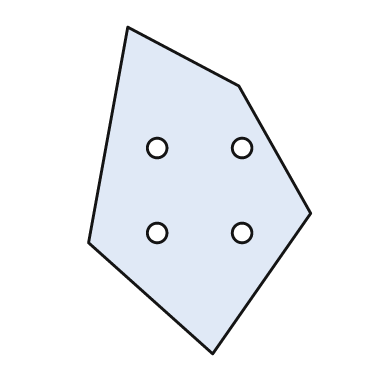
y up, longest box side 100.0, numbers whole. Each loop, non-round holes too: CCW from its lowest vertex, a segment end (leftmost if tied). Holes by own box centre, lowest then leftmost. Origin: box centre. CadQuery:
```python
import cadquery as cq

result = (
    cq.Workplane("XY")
    .moveTo(4.0, -50.0)
    .lineTo(34.0, -7.0)
    .lineTo(12.0, 32.0)
    .lineTo(-22.0, 50.0)
    .lineTo(-34.0, -16.0)
    .close()
    .moveTo(-13.0, -13.0)
    .circle(3.0)
    .moveTo(13.0, -13.0)
    .circle(3.0)
    .moveTo(-13.0, 13.0)
    .circle(3.0)
    .moveTo(13.0, 13.0)
    .circle(3.0)
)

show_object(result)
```